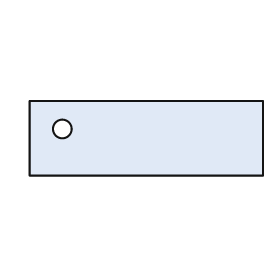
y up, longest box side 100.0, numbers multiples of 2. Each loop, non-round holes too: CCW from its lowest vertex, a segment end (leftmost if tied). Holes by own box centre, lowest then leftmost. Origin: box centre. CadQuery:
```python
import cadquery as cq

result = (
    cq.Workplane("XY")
    .moveTo(-50.0, -16.0)
    .lineTo(50.0, -16.0)
    .lineTo(50.0, 16.0)
    .lineTo(-50.0, 16.0)
    .close()
    .moveTo(-36.0, 4.0)
    .circle(4.0)
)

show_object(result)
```